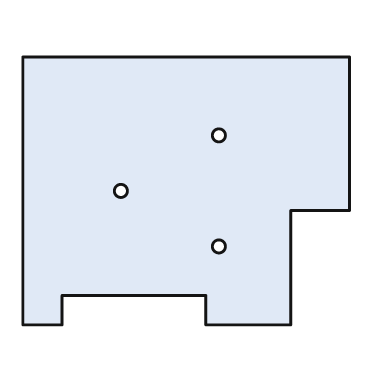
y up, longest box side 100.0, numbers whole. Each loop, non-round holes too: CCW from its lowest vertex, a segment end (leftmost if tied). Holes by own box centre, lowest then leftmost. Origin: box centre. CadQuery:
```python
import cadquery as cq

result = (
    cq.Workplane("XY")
    .moveTo(-50.0, -41.0)
    .lineTo(-38.0, -41.0)
    .lineTo(-38.0, -32.0)
    .lineTo(6.0, -32.0)
    .lineTo(6.0, -41.0)
    .lineTo(32.0, -41.0)
    .lineTo(32.0, -6.0)
    .lineTo(50.0, -6.0)
    .lineTo(50.0, 41.0)
    .lineTo(-50.0, 41.0)
    .close()
    .moveTo(10.0, -17.0)
    .circle(2.0)
    .moveTo(-20.0, 0.0)
    .circle(2.0)
    .moveTo(10.0, 17.0)
    .circle(2.0)
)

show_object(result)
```